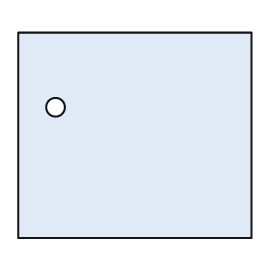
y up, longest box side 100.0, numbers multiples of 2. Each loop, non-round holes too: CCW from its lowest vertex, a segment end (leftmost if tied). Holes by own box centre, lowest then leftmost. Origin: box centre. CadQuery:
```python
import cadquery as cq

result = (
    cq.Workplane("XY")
    .moveTo(-50.0, -44.0)
    .lineTo(50.0, -44.0)
    .lineTo(50.0, 44.0)
    .lineTo(-50.0, 44.0)
    .close()
    .moveTo(-34.0, 12.0)
    .circle(4.0)
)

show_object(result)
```